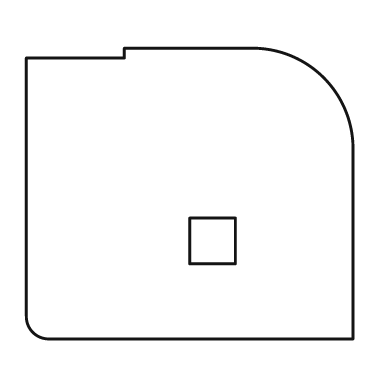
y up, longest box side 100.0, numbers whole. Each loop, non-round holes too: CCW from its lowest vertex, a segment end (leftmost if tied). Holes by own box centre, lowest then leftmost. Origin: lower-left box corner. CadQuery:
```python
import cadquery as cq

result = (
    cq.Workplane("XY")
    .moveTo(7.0, 0.0)
    .lineTo(100.0, 0.0)
    .lineTo(100.0, 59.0)
    .threePointArc((91.0, 80.0), (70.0, 89.0))
    .lineTo(30.0, 89.0)
    .lineTo(30.0, 86.0)
    .lineTo(0.0, 86.0)
    .lineTo(0.0, 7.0)
    .threePointArc((2.0, 2.0), (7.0, 0.0))
    .close()
    .moveTo(50.0, 23.0)
    .lineTo(64.0, 23.0)
    .lineTo(64.0, 37.0)
    .lineTo(50.0, 37.0)
    .close()
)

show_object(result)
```